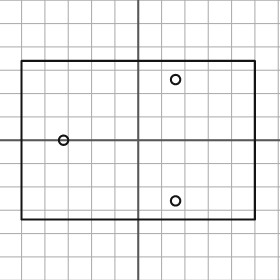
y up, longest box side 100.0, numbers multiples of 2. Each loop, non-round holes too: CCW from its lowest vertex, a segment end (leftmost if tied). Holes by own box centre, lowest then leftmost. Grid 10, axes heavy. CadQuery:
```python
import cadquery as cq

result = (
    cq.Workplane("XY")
    .moveTo(-50.0, -34.0)
    .lineTo(50.0, -34.0)
    .lineTo(50.0, 34.0)
    .lineTo(-50.0, 34.0)
    .close()
    .moveTo(16.0, -26.0)
    .circle(2.0)
    .moveTo(-32.0, 0.0)
    .circle(2.0)
    .moveTo(16.0, 26.0)
    .circle(2.0)
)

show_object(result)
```